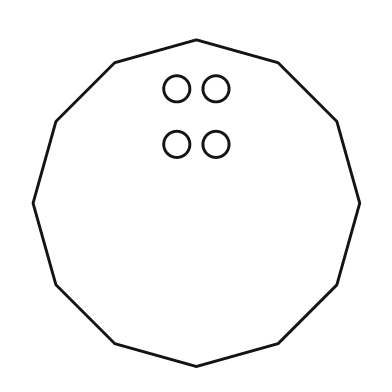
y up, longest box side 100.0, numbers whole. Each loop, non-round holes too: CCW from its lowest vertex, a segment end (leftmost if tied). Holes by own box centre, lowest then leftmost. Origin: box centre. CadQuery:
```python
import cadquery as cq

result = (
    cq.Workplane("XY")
    .moveTo(0.0, -50.0)
    .lineTo(25.0, -43.0)
    .lineTo(43.0, -25.0)
    .lineTo(50.0, 0.0)
    .lineTo(43.0, 25.0)
    .lineTo(25.0, 43.0)
    .lineTo(0.0, 50.0)
    .lineTo(-25.0, 43.0)
    .lineTo(-43.0, 25.0)
    .lineTo(-50.0, 0.0)
    .lineTo(-43.0, -25.0)
    .lineTo(-25.0, -43.0)
    .close()
    .moveTo(-6.0, 18.0)
    .circle(4.0)
    .moveTo(6.0, 18.0)
    .circle(4.0)
    .moveTo(-6.0, 35.0)
    .circle(4.0)
    .moveTo(6.0, 35.0)
    .circle(4.0)
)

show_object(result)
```